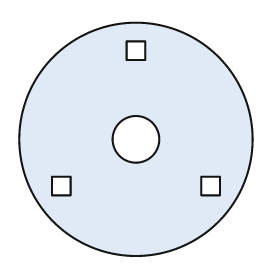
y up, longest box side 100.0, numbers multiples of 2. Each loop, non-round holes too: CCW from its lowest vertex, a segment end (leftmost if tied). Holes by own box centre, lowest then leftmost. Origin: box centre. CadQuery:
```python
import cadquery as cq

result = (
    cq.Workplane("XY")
    .moveTo(0.0, 0.0)
    .circle(50.0)
    .moveTo(-36.0, -24.0)
    .lineTo(-28.0, -24.0)
    .lineTo(-28.0, -16.0)
    .lineTo(-36.0, -16.0)
    .close()
    .moveTo(28.0, -24.0)
    .lineTo(36.0, -24.0)
    .lineTo(36.0, -16.0)
    .lineTo(28.0, -16.0)
    .close()
    .moveTo(0.0, 0.0)
    .circle(10.0)
    .moveTo(-4.0, 34.0)
    .lineTo(4.0, 34.0)
    .lineTo(4.0, 42.0)
    .lineTo(-4.0, 42.0)
    .close()
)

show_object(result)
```